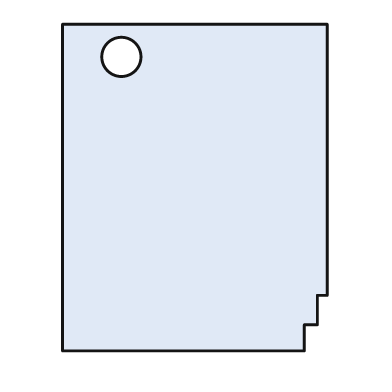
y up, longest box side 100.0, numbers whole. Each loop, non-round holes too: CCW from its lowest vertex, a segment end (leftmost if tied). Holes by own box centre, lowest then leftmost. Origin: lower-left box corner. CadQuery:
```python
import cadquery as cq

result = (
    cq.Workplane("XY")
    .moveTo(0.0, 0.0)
    .lineTo(74.0, 0.0)
    .lineTo(74.0, 8.0)
    .lineTo(78.0, 8.0)
    .lineTo(78.0, 17.0)
    .lineTo(81.0, 17.0)
    .lineTo(81.0, 100.0)
    .lineTo(0.0, 100.0)
    .close()
    .moveTo(18.0, 90.0)
    .circle(6.0)
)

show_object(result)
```